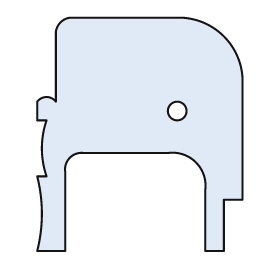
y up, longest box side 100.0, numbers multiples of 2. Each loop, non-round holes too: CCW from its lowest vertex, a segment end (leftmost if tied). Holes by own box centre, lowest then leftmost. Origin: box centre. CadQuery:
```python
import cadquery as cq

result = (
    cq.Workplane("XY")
    .moveTo(-44.0, -50.0)
    .lineTo(-32.0, -50.0)
    .lineTo(-32.0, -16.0)
    .threePointArc((-30.0, -10.0), (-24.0, -8.0))
    .lineTo(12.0, -8.0)
    .threePointArc((24.0, -12.0), (28.0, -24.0))
    .lineTo(28.0, -50.0)
    .lineTo(36.0, -50.0)
    .lineTo(36.0, -28.0)
    .lineTo(44.0, -28.0)
    .lineTo(44.0, 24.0)
    .threePointArc((36.0, 42.0), (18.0, 50.0))
    .lineTo(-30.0, 50.0)
    .threePointArc((-34.0, 48.0), (-36.0, 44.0))
    .lineTo(-36.0, 14.0)
    .threePointArc((-40.0, 16.0), (-44.0, 14.0))
    .lineTo(-44.0, 6.0)
    .lineTo(-40.0, 6.0)
    .threePointArc((-42.0, -6.0), (-40.0, -18.0))
    .lineTo(-44.0, -18.0)
    .threePointArc((-42.0, -34.0), (-44.0, -50.0))
    .close()
    .moveTo(16.0, 10.0)
    .circle(4.0)
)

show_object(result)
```